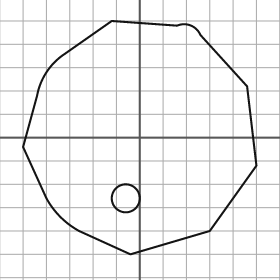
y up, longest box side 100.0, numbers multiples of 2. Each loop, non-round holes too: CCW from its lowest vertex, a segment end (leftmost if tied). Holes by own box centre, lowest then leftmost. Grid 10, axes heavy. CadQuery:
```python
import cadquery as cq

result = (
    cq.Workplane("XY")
    .moveTo(-4.0, -50.0)
    .lineTo(30.0, -40.0)
    .lineTo(50.0, -12.0)
    .lineTo(46.0, 22.0)
    .lineTo(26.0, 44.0)
    .threePointArc((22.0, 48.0), (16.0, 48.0))
    .lineTo(-12.0, 50.0)
    .lineTo(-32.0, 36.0)
    .threePointArc((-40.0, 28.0), (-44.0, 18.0))
    .lineTo(-50.0, -4.0)
    .lineTo(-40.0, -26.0)
    .threePointArc((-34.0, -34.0), (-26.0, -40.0))
    .close()
    .moveTo(-6.0, -26.0)
    .circle(6.0)
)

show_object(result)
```